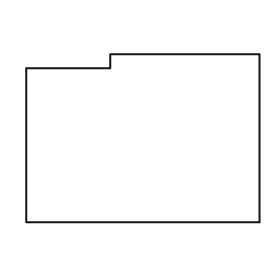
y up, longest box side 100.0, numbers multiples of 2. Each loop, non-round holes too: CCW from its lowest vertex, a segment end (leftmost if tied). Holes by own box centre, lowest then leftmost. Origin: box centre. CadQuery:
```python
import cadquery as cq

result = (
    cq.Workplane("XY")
    .moveTo(-50.0, -36.0)
    .lineTo(50.0, -36.0)
    .lineTo(50.0, 36.0)
    .lineTo(-14.0, 36.0)
    .lineTo(-14.0, 30.0)
    .lineTo(-50.0, 30.0)
    .close()
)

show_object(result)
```